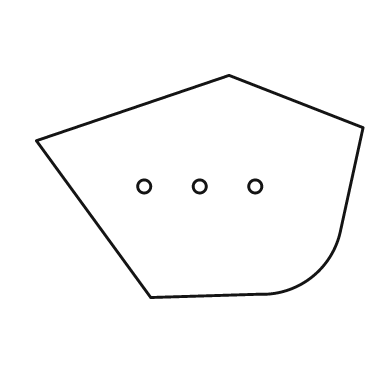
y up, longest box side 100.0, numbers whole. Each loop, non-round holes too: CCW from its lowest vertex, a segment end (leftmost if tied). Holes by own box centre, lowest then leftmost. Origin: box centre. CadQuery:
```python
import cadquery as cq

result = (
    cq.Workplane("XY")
    .moveTo(-15.0, -34.0)
    .lineTo(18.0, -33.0)
    .threePointArc((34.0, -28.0), (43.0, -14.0))
    .lineTo(50.0, 18.0)
    .lineTo(9.0, 34.0)
    .lineTo(-50.0, 14.0)
    .close()
    .moveTo(-17.0, 0.0)
    .circle(2.0)
    .moveTo(0.0, 0.0)
    .circle(2.0)
    .moveTo(17.0, 0.0)
    .circle(2.0)
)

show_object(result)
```